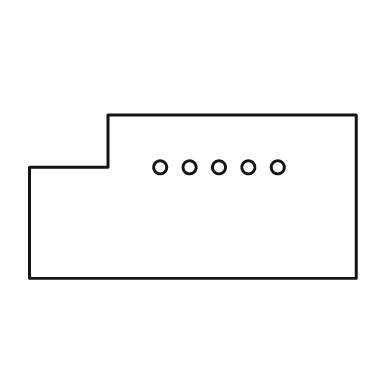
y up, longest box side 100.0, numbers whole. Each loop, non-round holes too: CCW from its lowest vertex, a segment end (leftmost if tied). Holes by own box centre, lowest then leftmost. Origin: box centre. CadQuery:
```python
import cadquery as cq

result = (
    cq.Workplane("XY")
    .moveTo(-50.0, -25.0)
    .lineTo(50.0, -25.0)
    .lineTo(50.0, 25.0)
    .lineTo(-26.0, 25.0)
    .lineTo(-26.0, 9.0)
    .lineTo(-50.0, 9.0)
    .close()
    .moveTo(-10.0, 9.0)
    .circle(2.0)
    .moveTo(-1.0, 9.0)
    .circle(2.0)
    .moveTo(8.0, 9.0)
    .circle(2.0)
    .moveTo(17.0, 9.0)
    .circle(2.0)
    .moveTo(26.0, 9.0)
    .circle(2.0)
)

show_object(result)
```